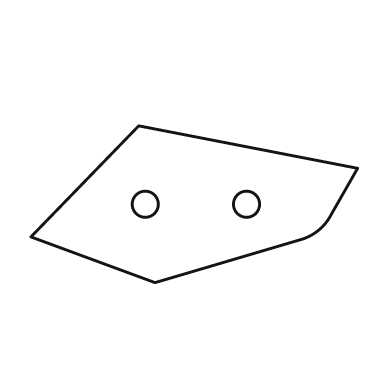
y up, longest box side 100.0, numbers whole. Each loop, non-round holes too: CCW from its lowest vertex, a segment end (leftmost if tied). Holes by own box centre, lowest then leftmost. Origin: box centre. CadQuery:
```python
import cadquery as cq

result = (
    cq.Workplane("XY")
    .moveTo(-12.0, -24.0)
    .lineTo(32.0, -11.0)
    .threePointArc((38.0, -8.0), (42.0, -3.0))
    .lineTo(50.0, 11.0)
    .lineTo(-17.0, 24.0)
    .lineTo(-50.0, -10.0)
    .close()
    .moveTo(-15.0, 0.0)
    .circle(4.0)
    .moveTo(16.0, 0.0)
    .circle(4.0)
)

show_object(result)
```